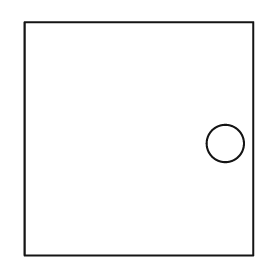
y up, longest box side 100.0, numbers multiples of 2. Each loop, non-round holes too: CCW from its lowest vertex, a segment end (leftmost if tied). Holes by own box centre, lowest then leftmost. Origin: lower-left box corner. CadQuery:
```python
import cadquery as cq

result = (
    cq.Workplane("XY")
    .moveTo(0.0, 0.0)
    .lineTo(98.0, 0.0)
    .lineTo(98.0, 100.0)
    .lineTo(0.0, 100.0)
    .close()
    .moveTo(86.0, 48.0)
    .circle(8.0)
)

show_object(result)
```